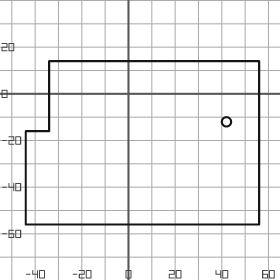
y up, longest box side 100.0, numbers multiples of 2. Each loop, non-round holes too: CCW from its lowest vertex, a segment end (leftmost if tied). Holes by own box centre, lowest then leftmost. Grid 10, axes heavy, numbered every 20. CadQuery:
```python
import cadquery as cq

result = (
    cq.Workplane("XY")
    .moveTo(-44.0, -56.0)
    .lineTo(56.0, -56.0)
    .lineTo(56.0, 14.0)
    .lineTo(-34.0, 14.0)
    .lineTo(-34.0, -16.0)
    .lineTo(-44.0, -16.0)
    .close()
    .moveTo(42.0, -12.0)
    .circle(2.0)
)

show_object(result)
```